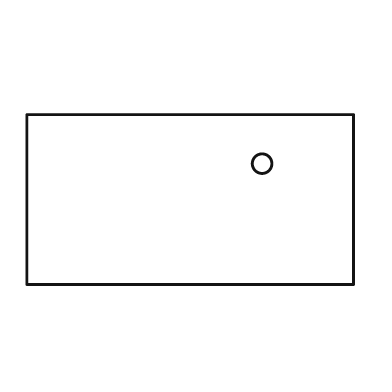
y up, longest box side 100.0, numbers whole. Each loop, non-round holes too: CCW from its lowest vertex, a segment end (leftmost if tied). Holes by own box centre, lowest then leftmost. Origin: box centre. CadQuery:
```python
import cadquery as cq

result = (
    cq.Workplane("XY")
    .moveTo(-50.0, -26.0)
    .lineTo(50.0, -26.0)
    .lineTo(50.0, 26.0)
    .lineTo(-50.0, 26.0)
    .close()
    .moveTo(22.0, 11.0)
    .circle(3.0)
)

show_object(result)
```